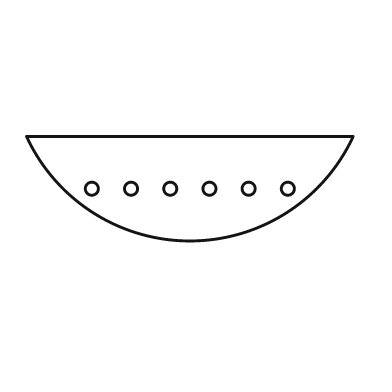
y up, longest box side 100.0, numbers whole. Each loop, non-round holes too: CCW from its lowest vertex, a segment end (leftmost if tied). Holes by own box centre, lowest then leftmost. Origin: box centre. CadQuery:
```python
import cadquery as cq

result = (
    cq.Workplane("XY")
    .moveTo(-50.0, 16.0)
    .threePointArc((0.0, -16.0), (50.0, 16.0))
    .close()
    .moveTo(-30.0, 0.0)
    .circle(2.0)
    .moveTo(-18.0, 0.0)
    .circle(2.0)
    .moveTo(-6.0, 0.0)
    .circle(2.0)
    .moveTo(6.0, 0.0)
    .circle(2.0)
    .moveTo(18.0, 0.0)
    .circle(2.0)
    .moveTo(30.0, 0.0)
    .circle(2.0)
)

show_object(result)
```